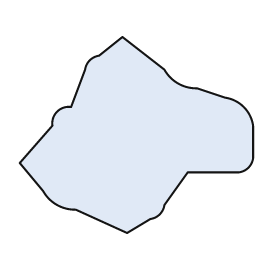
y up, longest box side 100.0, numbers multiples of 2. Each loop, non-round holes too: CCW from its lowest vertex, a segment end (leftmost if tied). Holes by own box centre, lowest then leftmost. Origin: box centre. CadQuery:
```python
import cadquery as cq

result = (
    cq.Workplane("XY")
    .moveTo(-4.0, -42.0)
    .lineTo(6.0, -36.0)
    .threePointArc((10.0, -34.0), (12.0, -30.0))
    .lineTo(22.0, -16.0)
    .lineTo(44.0, -16.0)
    .threePointArc((48.0, -14.0), (50.0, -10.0))
    .lineTo(50.0, 4.0)
    .threePointArc((46.0, 12.0), (38.0, 16.0))
    .lineTo(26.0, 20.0)
    .threePointArc((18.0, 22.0), (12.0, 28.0))
    .lineTo(-6.0, 42.0)
    .lineTo(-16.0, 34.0)
    .threePointArc((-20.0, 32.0), (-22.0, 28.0))
    .lineTo(-28.0, 12.0)
    .threePointArc((-34.0, 10.0), (-36.0, 4.0))
    .lineTo(-50.0, -12.0)
    .lineTo(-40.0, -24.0)
    .threePointArc((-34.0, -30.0), (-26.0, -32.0))
    .close()
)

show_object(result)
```